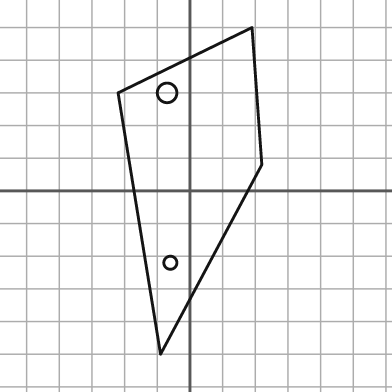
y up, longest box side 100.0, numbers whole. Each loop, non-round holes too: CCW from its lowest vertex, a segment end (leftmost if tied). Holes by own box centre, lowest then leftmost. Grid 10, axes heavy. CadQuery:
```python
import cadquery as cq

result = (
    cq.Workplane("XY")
    .moveTo(-9.0, -50.0)
    .lineTo(22.0, 8.0)
    .lineTo(19.0, 50.0)
    .lineTo(-22.0, 30.0)
    .close()
    .moveTo(-6.0, -22.0)
    .circle(2.0)
    .moveTo(-7.0, 30.0)
    .circle(3.0)
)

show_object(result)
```